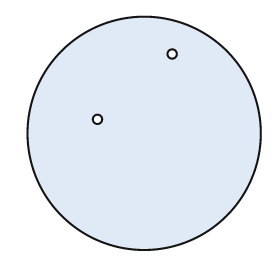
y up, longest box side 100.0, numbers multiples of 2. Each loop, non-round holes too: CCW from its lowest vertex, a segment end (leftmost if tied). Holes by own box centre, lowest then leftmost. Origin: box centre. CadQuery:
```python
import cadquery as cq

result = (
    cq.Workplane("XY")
    .moveTo(0.0, 0.0)
    .circle(50.0)
    .moveTo(-20.0, 6.0)
    .circle(2.0)
    .moveTo(12.0, 34.0)
    .circle(2.0)
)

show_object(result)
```